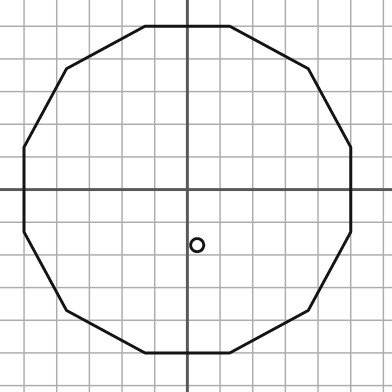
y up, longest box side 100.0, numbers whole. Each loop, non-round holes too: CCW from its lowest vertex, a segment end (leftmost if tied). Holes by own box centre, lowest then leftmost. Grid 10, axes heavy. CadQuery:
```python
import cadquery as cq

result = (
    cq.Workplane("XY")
    .moveTo(-13.0, -50.0)
    .lineTo(13.0, -50.0)
    .lineTo(37.0, -37.0)
    .lineTo(50.0, -13.0)
    .lineTo(50.0, 13.0)
    .lineTo(37.0, 37.0)
    .lineTo(13.0, 50.0)
    .lineTo(-13.0, 50.0)
    .lineTo(-37.0, 37.0)
    .lineTo(-50.0, 13.0)
    .lineTo(-50.0, -13.0)
    .lineTo(-37.0, -37.0)
    .close()
    .moveTo(3.0, -17.0)
    .circle(2.0)
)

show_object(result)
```